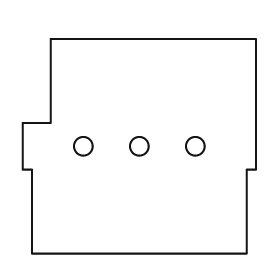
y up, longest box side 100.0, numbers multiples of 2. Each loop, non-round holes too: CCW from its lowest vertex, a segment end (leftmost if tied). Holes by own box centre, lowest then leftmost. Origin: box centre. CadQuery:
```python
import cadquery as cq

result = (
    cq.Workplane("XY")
    .moveTo(-46.0, -46.0)
    .lineTo(46.0, -46.0)
    .lineTo(46.0, -10.0)
    .lineTo(50.0, -10.0)
    .lineTo(50.0, 46.0)
    .lineTo(-38.0, 46.0)
    .lineTo(-38.0, 10.0)
    .lineTo(-50.0, 10.0)
    .lineTo(-50.0, -10.0)
    .lineTo(-46.0, -10.0)
    .close()
    .moveTo(-24.0, 0.0)
    .circle(4.0)
    .moveTo(0.0, 0.0)
    .circle(4.0)
    .moveTo(24.0, 0.0)
    .circle(4.0)
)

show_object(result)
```